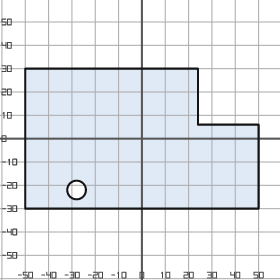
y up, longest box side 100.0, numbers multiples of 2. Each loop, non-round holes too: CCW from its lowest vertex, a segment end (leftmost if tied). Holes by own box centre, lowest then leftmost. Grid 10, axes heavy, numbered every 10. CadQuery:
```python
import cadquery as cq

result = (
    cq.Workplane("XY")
    .moveTo(-50.0, -30.0)
    .lineTo(50.0, -30.0)
    .lineTo(50.0, 6.0)
    .lineTo(24.0, 6.0)
    .lineTo(24.0, 30.0)
    .lineTo(-50.0, 30.0)
    .close()
    .moveTo(-28.0, -22.0)
    .circle(4.0)
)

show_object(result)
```